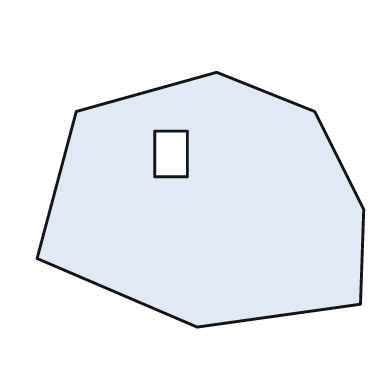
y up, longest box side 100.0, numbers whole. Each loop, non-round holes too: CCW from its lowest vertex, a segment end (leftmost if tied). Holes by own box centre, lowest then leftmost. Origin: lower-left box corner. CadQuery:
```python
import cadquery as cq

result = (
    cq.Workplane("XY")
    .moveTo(49.0, 0.0)
    .lineTo(99.0, 7.0)
    .lineTo(100.0, 36.0)
    .lineTo(85.0, 66.0)
    .lineTo(55.0, 78.0)
    .lineTo(12.0, 66.0)
    .lineTo(0.0, 21.0)
    .close()
    .moveTo(36.0, 46.0)
    .lineTo(46.0, 46.0)
    .lineTo(46.0, 60.0)
    .lineTo(36.0, 60.0)
    .close()
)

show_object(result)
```